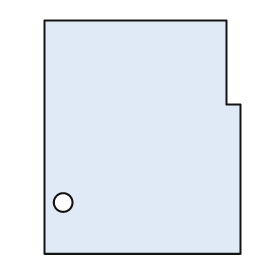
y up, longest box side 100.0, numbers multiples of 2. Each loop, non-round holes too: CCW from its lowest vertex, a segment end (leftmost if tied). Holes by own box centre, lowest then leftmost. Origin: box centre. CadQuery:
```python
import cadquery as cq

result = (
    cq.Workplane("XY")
    .moveTo(-42.0, -50.0)
    .lineTo(42.0, -50.0)
    .lineTo(42.0, 14.0)
    .lineTo(36.0, 14.0)
    .lineTo(36.0, 50.0)
    .lineTo(-42.0, 50.0)
    .close()
    .moveTo(-34.0, -28.0)
    .circle(4.0)
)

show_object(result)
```